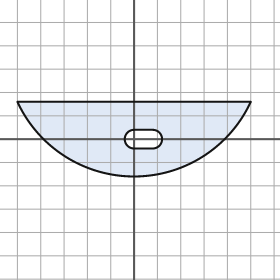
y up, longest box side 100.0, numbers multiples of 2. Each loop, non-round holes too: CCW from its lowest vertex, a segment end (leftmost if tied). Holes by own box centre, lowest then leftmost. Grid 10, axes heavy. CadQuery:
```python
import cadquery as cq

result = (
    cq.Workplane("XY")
    .moveTo(-50.0, 16.0)
    .threePointArc((0.0, -16.0), (50.0, 16.0))
    .close()
    .moveTo(0.0, -4.0)
    .lineTo(8.0, -4.0)
    .threePointArc((12.0, 0.0), (8.0, 4.0))
    .lineTo(0.0, 4.0)
    .threePointArc((-4.0, 0.0), (0.0, -4.0))
    .close()
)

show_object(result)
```